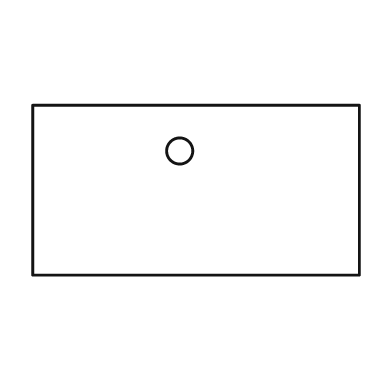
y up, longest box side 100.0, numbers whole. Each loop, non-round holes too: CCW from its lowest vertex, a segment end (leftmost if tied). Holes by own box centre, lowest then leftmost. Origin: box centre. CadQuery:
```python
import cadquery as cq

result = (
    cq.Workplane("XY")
    .moveTo(-50.0, -26.0)
    .lineTo(50.0, -26.0)
    .lineTo(50.0, 26.0)
    .lineTo(-50.0, 26.0)
    .close()
    .moveTo(-5.0, 12.0)
    .circle(4.0)
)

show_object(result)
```